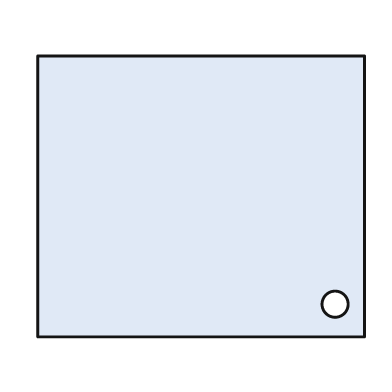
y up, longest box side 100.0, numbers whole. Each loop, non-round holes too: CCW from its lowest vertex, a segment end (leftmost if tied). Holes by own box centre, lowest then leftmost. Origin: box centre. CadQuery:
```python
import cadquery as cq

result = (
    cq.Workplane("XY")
    .moveTo(-50.0, -43.0)
    .lineTo(50.0, -43.0)
    .lineTo(50.0, 43.0)
    .lineTo(-50.0, 43.0)
    .close()
    .moveTo(41.0, -33.0)
    .circle(4.0)
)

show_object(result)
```